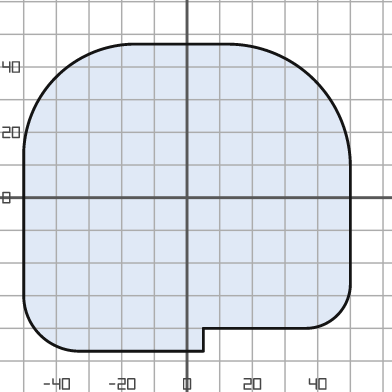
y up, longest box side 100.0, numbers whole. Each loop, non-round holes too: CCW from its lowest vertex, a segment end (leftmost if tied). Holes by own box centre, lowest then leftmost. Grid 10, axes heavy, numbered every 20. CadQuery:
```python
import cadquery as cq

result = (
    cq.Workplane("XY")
    .moveTo(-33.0, -47.0)
    .lineTo(5.0, -47.0)
    .lineTo(5.0, -40.0)
    .lineTo(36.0, -40.0)
    .threePointArc((46.0, -36.0), (50.0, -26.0))
    .lineTo(50.0, 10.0)
    .threePointArc((39.0, 36.0), (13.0, 47.0))
    .lineTo(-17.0, 47.0)
    .threePointArc((-40.0, 37.0), (-50.0, 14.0))
    .lineTo(-50.0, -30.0)
    .threePointArc((-45.0, -42.0), (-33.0, -47.0))
    .close()
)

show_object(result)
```